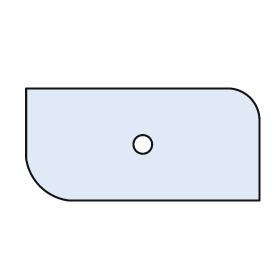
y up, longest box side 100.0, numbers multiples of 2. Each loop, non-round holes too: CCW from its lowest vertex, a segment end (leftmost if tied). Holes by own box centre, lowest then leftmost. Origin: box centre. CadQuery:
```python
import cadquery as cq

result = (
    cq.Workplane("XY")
    .moveTo(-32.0, -24.0)
    .lineTo(50.0, -24.0)
    .lineTo(50.0, 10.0)
    .threePointArc((46.0, 20.0), (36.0, 24.0))
    .lineTo(-50.0, 24.0)
    .lineTo(-50.0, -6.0)
    .threePointArc((-44.0, -18.0), (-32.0, -24.0))
    .close()
    .moveTo(0.0, 0.0)
    .circle(4.0)
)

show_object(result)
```